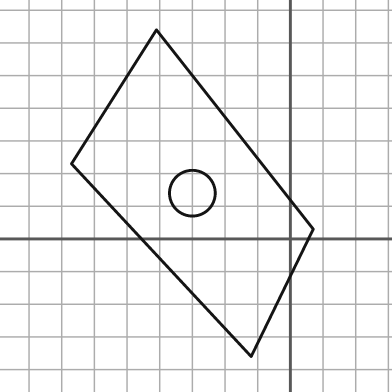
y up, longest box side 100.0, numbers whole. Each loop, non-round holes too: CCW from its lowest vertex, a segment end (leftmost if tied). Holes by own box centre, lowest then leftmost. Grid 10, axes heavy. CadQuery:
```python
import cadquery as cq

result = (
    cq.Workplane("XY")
    .moveTo(-12.0, -36.0)
    .lineTo(7.0, 3.0)
    .lineTo(-41.0, 64.0)
    .lineTo(-67.0, 23.0)
    .close()
    .moveTo(-30.0, 14.0)
    .circle(7.0)
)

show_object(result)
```